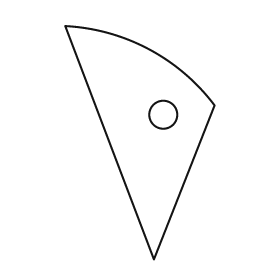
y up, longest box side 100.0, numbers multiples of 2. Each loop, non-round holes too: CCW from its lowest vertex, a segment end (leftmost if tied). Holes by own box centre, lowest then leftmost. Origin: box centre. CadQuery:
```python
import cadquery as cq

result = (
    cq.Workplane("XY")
    .moveTo(6.0, -50.0)
    .lineTo(32.0, 16.0)
    .threePointArc((4.0, 40.0), (-32.0, 50.0))
    .close()
    .moveTo(10.0, 12.0)
    .circle(6.0)
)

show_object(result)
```